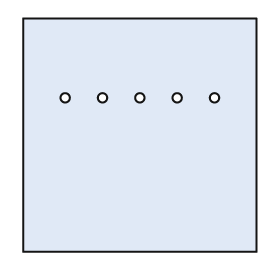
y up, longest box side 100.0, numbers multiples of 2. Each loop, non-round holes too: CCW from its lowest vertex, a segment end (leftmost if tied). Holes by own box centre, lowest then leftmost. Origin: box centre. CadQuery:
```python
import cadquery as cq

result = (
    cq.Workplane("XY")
    .moveTo(-50.0, -50.0)
    .lineTo(50.0, -50.0)
    .lineTo(50.0, 50.0)
    .lineTo(-50.0, 50.0)
    .close()
    .moveTo(-32.0, 16.0)
    .circle(2.0)
    .moveTo(-16.0, 16.0)
    .circle(2.0)
    .moveTo(0.0, 16.0)
    .circle(2.0)
    .moveTo(16.0, 16.0)
    .circle(2.0)
    .moveTo(32.0, 16.0)
    .circle(2.0)
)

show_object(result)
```